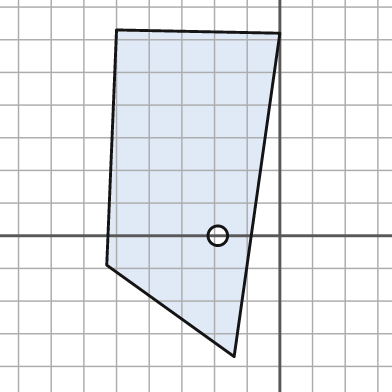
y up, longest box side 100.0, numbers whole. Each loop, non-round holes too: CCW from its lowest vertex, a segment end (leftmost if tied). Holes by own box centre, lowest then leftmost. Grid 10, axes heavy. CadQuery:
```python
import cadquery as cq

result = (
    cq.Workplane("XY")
    .moveTo(-14.0, -37.0)
    .lineTo(0.0, 62.0)
    .lineTo(-50.0, 63.0)
    .lineTo(-53.0, -9.0)
    .close()
    .moveTo(-19.0, 0.0)
    .circle(3.0)
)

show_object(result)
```